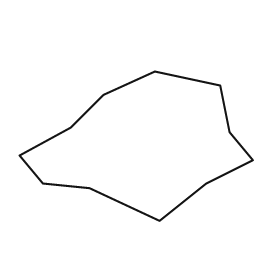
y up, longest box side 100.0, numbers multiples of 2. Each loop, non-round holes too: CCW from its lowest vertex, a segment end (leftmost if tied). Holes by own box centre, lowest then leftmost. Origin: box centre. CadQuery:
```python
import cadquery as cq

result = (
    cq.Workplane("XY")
    .moveTo(10.0, -32.0)
    .lineTo(30.0, -16.0)
    .lineTo(50.0, -6.0)
    .lineTo(40.0, 6.0)
    .lineTo(36.0, 26.0)
    .lineTo(8.0, 32.0)
    .lineTo(-14.0, 22.0)
    .lineTo(-28.0, 8.0)
    .lineTo(-50.0, -4.0)
    .lineTo(-40.0, -16.0)
    .lineTo(-20.0, -18.0)
    .close()
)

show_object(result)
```